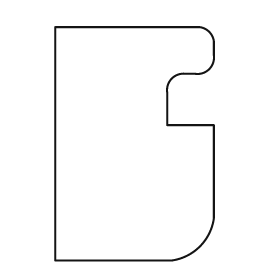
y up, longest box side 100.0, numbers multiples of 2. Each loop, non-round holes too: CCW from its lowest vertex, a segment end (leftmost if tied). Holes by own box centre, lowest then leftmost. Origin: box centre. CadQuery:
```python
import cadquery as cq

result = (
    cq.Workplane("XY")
    .moveTo(-34.0, -50.0)
    .lineTo(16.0, -50.0)
    .threePointArc((28.0, -44.0), (34.0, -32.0))
    .lineTo(34.0, 8.0)
    .lineTo(14.0, 8.0)
    .lineTo(14.0, 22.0)
    .threePointArc((16.0, 28.0), (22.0, 30.0))
    .lineTo(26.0, 30.0)
    .threePointArc((32.0, 32.0), (34.0, 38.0))
    .lineTo(34.0, 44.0)
    .threePointArc((32.0, 48.0), (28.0, 50.0))
    .lineTo(-34.0, 50.0)
    .close()
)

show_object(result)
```